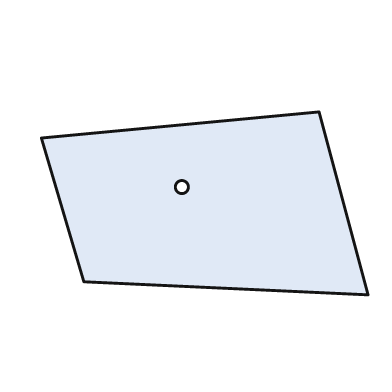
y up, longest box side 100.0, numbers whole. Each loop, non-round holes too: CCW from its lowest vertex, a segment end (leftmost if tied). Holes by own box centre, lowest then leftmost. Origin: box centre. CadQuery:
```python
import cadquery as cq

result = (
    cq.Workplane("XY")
    .moveTo(50.0, -28.0)
    .lineTo(35.0, 28.0)
    .lineTo(-50.0, 20.0)
    .lineTo(-37.0, -24.0)
    .close()
    .moveTo(-7.0, 5.0)
    .circle(2.0)
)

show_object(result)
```